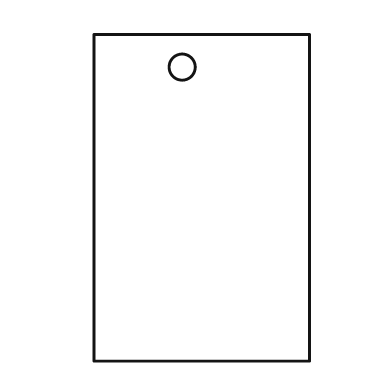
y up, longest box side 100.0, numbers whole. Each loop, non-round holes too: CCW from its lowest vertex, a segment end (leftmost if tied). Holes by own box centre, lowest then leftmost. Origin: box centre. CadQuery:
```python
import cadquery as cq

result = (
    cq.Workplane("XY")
    .moveTo(-33.0, -50.0)
    .lineTo(33.0, -50.0)
    .lineTo(33.0, 50.0)
    .lineTo(-33.0, 50.0)
    .close()
    .moveTo(-6.0, 40.0)
    .circle(4.0)
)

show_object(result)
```